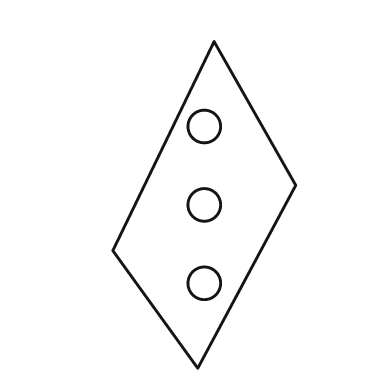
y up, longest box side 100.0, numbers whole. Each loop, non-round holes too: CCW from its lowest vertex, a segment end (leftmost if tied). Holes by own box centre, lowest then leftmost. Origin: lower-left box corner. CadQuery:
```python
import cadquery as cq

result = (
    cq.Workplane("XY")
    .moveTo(26.0, 0.0)
    .lineTo(56.0, 56.0)
    .lineTo(31.0, 100.0)
    .lineTo(0.0, 36.0)
    .close()
    .moveTo(28.0, 26.0)
    .circle(5.0)
    .moveTo(28.0, 50.0)
    .circle(5.0)
    .moveTo(28.0, 74.0)
    .circle(5.0)
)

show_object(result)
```